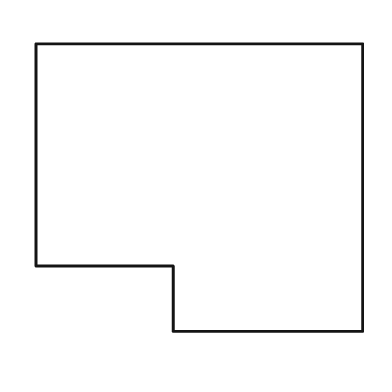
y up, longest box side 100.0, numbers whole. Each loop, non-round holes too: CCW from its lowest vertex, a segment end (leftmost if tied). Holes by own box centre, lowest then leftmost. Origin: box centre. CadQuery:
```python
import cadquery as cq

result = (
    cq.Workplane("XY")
    .moveTo(-8.0, -44.0)
    .lineTo(50.0, -44.0)
    .lineTo(50.0, 44.0)
    .lineTo(-50.0, 44.0)
    .lineTo(-50.0, -24.0)
    .lineTo(-8.0, -24.0)
    .close()
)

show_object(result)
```